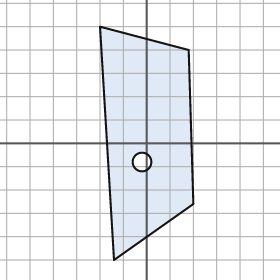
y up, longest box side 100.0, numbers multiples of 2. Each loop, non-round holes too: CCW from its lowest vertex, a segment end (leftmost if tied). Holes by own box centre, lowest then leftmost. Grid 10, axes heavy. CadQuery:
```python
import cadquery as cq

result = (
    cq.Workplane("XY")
    .moveTo(-14.0, -50.0)
    .lineTo(20.0, -26.0)
    .lineTo(18.0, 40.0)
    .lineTo(-20.0, 50.0)
    .close()
    .moveTo(-2.0, -8.0)
    .circle(4.0)
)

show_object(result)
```